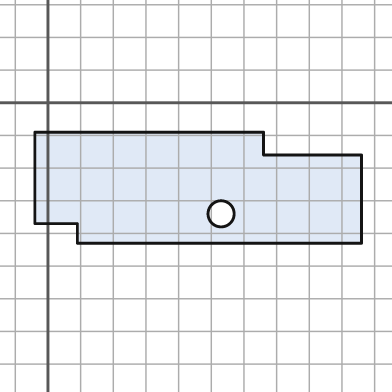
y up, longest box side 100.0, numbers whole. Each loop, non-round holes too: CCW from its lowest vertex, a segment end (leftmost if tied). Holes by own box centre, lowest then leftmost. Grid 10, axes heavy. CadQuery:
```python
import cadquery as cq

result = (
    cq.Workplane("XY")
    .moveTo(9.0, -43.0)
    .lineTo(96.0, -43.0)
    .lineTo(96.0, -16.0)
    .lineTo(66.0, -16.0)
    .lineTo(66.0, -9.0)
    .lineTo(-4.0, -9.0)
    .lineTo(-4.0, -37.0)
    .lineTo(9.0, -37.0)
    .close()
    .moveTo(53.0, -34.0)
    .circle(4.0)
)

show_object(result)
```